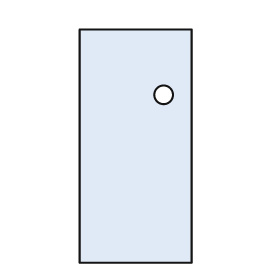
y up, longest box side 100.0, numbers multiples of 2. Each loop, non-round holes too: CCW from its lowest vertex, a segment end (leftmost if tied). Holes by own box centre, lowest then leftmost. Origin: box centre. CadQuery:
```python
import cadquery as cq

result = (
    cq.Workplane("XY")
    .moveTo(-24.0, -50.0)
    .lineTo(24.0, -50.0)
    .lineTo(24.0, 50.0)
    .lineTo(-24.0, 50.0)
    .close()
    .moveTo(12.0, 22.0)
    .circle(4.0)
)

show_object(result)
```